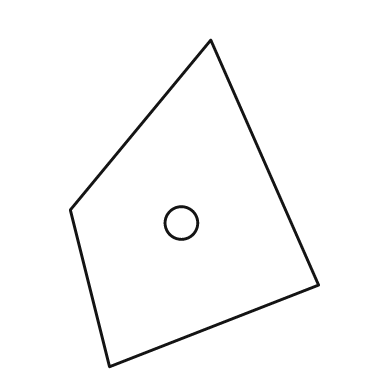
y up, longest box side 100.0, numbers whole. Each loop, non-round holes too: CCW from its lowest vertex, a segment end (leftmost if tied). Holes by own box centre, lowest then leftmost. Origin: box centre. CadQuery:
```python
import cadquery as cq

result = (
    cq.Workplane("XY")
    .moveTo(-26.0, -50.0)
    .lineTo(38.0, -25.0)
    .lineTo(5.0, 50.0)
    .lineTo(-38.0, -2.0)
    .close()
    .moveTo(-4.0, -6.0)
    .circle(5.0)
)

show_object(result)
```